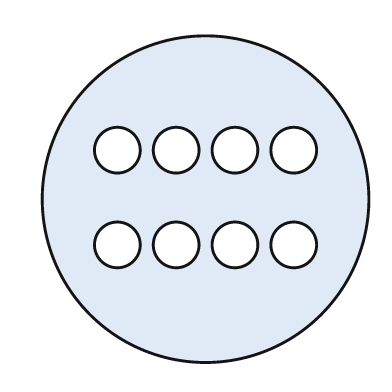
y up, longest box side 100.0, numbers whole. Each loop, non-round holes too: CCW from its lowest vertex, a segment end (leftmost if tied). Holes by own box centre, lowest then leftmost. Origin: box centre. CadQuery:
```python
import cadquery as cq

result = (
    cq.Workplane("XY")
    .moveTo(0.0, 0.0)
    .circle(50.0)
    .moveTo(-27.0, -14.0)
    .circle(7.0)
    .moveTo(-9.0, -14.0)
    .circle(7.0)
    .moveTo(9.0, -14.0)
    .circle(7.0)
    .moveTo(27.0, -14.0)
    .circle(7.0)
    .moveTo(-27.0, 15.0)
    .circle(7.0)
    .moveTo(-9.0, 15.0)
    .circle(7.0)
    .moveTo(9.0, 15.0)
    .circle(7.0)
    .moveTo(27.0, 15.0)
    .circle(7.0)
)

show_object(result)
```